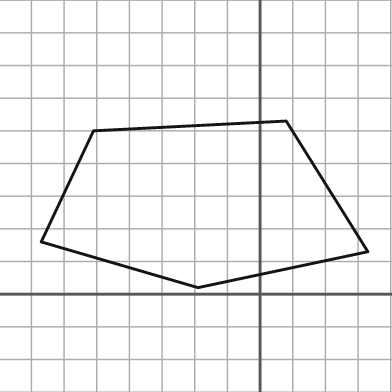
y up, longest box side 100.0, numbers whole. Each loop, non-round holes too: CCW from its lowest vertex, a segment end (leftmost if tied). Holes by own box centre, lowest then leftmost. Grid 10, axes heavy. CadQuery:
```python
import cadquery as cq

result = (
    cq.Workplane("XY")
    .moveTo(-19.0, 2.0)
    .lineTo(33.0, 13.0)
    .lineTo(8.0, 53.0)
    .lineTo(-51.0, 50.0)
    .lineTo(-67.0, 16.0)
    .close()
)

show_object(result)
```